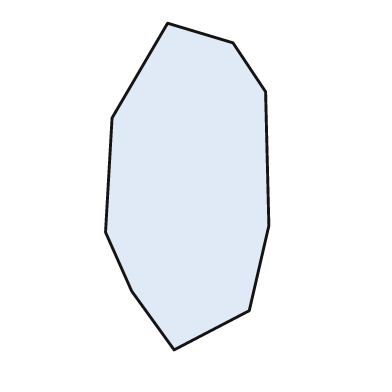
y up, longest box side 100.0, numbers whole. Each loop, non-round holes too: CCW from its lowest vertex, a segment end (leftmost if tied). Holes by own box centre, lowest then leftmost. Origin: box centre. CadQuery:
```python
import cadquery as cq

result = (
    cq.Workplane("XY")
    .moveTo(-4.0, -50.0)
    .lineTo(19.0, -38.0)
    .lineTo(25.0, -12.0)
    .lineTo(24.0, 29.0)
    .lineTo(14.0, 44.0)
    .lineTo(-6.0, 50.0)
    .lineTo(-23.0, 21.0)
    .lineTo(-25.0, -14.0)
    .lineTo(-17.0, -32.0)
    .close()
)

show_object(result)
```